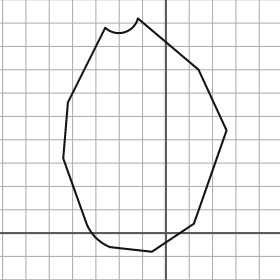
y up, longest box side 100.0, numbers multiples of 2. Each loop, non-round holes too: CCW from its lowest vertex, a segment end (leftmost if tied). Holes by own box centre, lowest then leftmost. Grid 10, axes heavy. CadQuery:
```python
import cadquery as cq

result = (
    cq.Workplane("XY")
    .moveTo(-6.0, -8.0)
    .lineTo(12.0, 4.0)
    .lineTo(26.0, 44.0)
    .lineTo(14.0, 70.0)
    .lineTo(-12.0, 92.0)
    .threePointArc((-18.0, 86.0), (-26.0, 88.0))
    .lineTo(-42.0, 56.0)
    .lineTo(-44.0, 32.0)
    .lineTo(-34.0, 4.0)
    .threePointArc((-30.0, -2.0), (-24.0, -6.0))
    .close()
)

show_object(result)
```